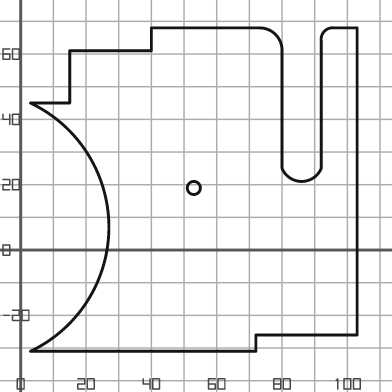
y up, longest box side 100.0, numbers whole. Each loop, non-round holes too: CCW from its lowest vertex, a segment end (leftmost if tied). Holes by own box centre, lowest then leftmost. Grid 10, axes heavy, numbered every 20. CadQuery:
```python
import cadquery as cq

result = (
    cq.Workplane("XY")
    .moveTo(3.0, -31.0)
    .lineTo(72.0, -31.0)
    .lineTo(72.0, -26.0)
    .lineTo(103.0, -26.0)
    .lineTo(103.0, 68.0)
    .lineTo(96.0, 68.0)
    .threePointArc((93.0, 67.0), (92.0, 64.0))
    .lineTo(92.0, 25.0)
    .threePointArc((86.0, 21.0), (80.0, 25.0))
    .lineTo(80.0, 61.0)
    .threePointArc((78.0, 66.0), (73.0, 68.0))
    .lineTo(40.0, 68.0)
    .lineTo(40.0, 61.0)
    .lineTo(15.0, 61.0)
    .lineTo(15.0, 45.0)
    .lineTo(3.0, 45.0)
    .threePointArc((27.0, 7.0), (3.0, -31.0))
    .close()
    .moveTo(53.0, 19.0)
    .circle(2.0)
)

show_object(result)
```